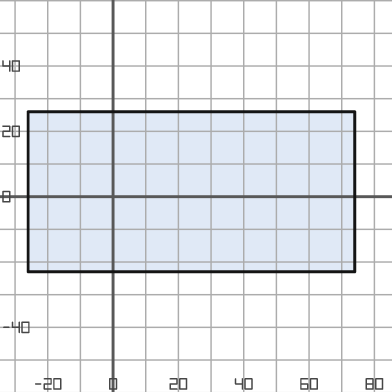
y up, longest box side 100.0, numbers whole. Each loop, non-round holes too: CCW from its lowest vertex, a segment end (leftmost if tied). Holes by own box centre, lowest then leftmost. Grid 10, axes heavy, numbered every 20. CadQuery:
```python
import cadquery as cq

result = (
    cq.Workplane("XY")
    .moveTo(-26.0, -23.0)
    .lineTo(74.0, -23.0)
    .lineTo(74.0, 26.0)
    .lineTo(-26.0, 26.0)
    .close()
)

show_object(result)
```